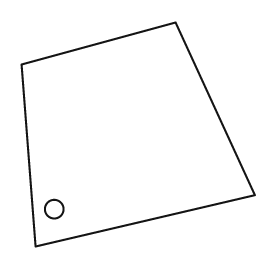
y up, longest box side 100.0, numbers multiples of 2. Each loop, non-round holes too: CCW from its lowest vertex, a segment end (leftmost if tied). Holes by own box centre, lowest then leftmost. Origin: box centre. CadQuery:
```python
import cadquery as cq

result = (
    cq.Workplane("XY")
    .moveTo(-44.0, -48.0)
    .lineTo(50.0, -26.0)
    .lineTo(16.0, 48.0)
    .lineTo(-50.0, 30.0)
    .close()
    .moveTo(-36.0, -32.0)
    .circle(4.0)
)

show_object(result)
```